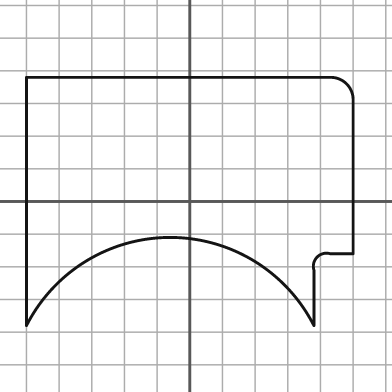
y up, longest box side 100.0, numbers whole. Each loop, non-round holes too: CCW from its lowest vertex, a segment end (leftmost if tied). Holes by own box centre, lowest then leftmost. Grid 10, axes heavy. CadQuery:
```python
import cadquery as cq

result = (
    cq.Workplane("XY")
    .moveTo(-50.0, -38.0)
    .threePointArc((-6.0, -11.0), (38.0, -38.0))
    .lineTo(38.0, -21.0)
    .threePointArc((39.0, -17.0), (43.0, -16.0))
    .lineTo(50.0, -16.0)
    .lineTo(50.0, 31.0)
    .threePointArc((48.0, 36.0), (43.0, 38.0))
    .lineTo(-50.0, 38.0)
    .close()
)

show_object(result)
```